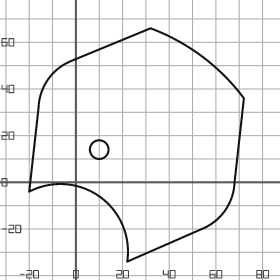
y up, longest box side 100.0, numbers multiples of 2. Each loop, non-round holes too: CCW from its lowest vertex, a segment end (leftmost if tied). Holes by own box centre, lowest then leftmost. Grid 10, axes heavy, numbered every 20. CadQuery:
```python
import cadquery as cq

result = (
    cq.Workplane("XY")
    .moveTo(22.0, -34.0)
    .lineTo(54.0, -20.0)
    .threePointArc((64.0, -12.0), (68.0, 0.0))
    .lineTo(72.0, 36.0)
    .threePointArc((54.0, 54.0), (32.0, 66.0))
    .lineTo(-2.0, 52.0)
    .threePointArc((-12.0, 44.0), (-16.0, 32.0))
    .lineTo(-20.0, -4.0)
    .threePointArc((10.0, -6.0), (22.0, -34.0))
    .close()
    .moveTo(10.0, 14.0)
    .circle(4.0)
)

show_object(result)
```